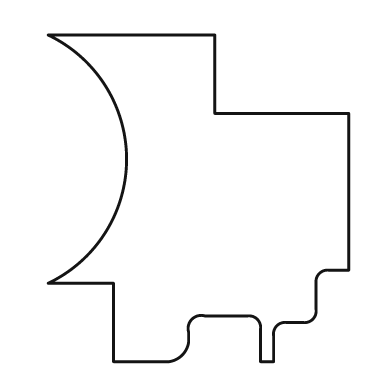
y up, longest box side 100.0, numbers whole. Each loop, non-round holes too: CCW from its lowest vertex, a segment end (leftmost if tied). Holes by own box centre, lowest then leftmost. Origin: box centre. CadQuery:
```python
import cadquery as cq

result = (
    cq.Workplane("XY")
    .moveTo(-26.0, -50.0)
    .lineTo(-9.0, -50.0)
    .threePointArc((-5.0, -48.0), (-3.0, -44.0))
    .lineTo(-3.0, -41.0)
    .threePointArc((-2.0, -37.0), (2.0, -36.0))
    .lineTo(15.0, -36.0)
    .threePointArc((18.0, -37.0), (19.0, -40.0))
    .lineTo(19.0, -50.0)
    .lineTo(23.0, -50.0)
    .lineTo(23.0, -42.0)
    .threePointArc((24.0, -39.0), (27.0, -38.0))
    .lineTo(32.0, -38.0)
    .threePointArc((35.0, -37.0), (36.0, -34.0))
    .lineTo(36.0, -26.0)
    .threePointArc((37.0, -23.0), (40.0, -22.0))
    .lineTo(46.0, -22.0)
    .lineTo(46.0, 26.0)
    .lineTo(5.0, 26.0)
    .lineTo(5.0, 50.0)
    .lineTo(-46.0, 50.0)
    .threePointArc((-22.0, 12.0), (-46.0, -26.0))
    .lineTo(-26.0, -26.0)
    .close()
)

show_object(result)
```